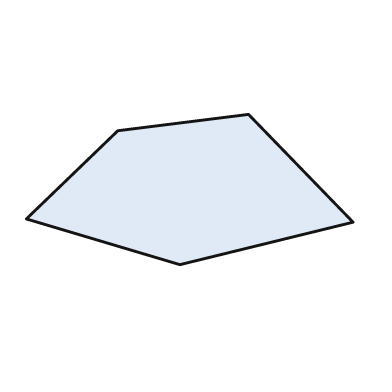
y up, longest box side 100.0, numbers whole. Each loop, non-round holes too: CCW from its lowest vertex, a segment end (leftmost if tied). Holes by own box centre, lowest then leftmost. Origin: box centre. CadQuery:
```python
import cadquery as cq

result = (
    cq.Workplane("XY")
    .moveTo(-3.0, -23.0)
    .lineTo(50.0, -10.0)
    .lineTo(18.0, 23.0)
    .lineTo(-22.0, 18.0)
    .lineTo(-50.0, -9.0)
    .close()
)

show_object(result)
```